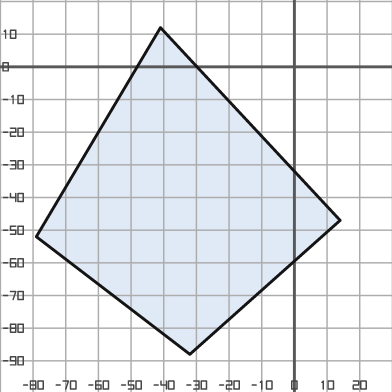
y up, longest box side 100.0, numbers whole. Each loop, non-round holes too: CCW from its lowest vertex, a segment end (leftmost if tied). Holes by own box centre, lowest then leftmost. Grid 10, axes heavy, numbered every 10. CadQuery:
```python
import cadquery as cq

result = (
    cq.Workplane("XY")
    .moveTo(-32.0, -88.0)
    .lineTo(14.0, -47.0)
    .lineTo(-41.0, 12.0)
    .lineTo(-79.0, -52.0)
    .close()
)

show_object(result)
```